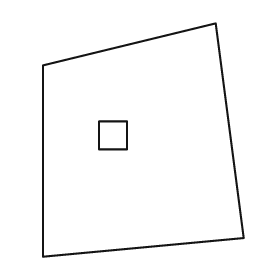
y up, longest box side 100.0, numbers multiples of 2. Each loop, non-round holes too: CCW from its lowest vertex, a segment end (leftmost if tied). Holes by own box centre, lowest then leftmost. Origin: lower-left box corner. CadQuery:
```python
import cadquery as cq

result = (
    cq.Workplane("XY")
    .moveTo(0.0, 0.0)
    .lineTo(86.0, 8.0)
    .lineTo(74.0, 100.0)
    .lineTo(0.0, 82.0)
    .close()
    .moveTo(24.0, 46.0)
    .lineTo(36.0, 46.0)
    .lineTo(36.0, 58.0)
    .lineTo(24.0, 58.0)
    .close()
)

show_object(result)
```